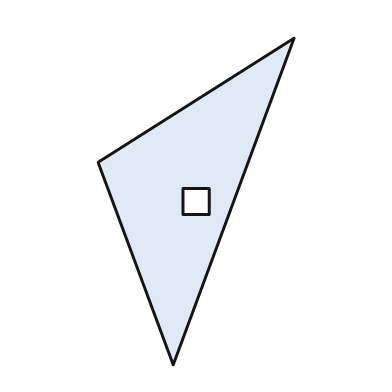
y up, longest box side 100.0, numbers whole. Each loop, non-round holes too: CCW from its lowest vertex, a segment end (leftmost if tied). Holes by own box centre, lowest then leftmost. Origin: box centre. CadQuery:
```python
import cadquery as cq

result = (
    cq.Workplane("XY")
    .moveTo(-7.0, -50.0)
    .lineTo(30.0, 50.0)
    .lineTo(-30.0, 12.0)
    .close()
    .moveTo(-4.0, -4.0)
    .lineTo(4.0, -4.0)
    .lineTo(4.0, 4.0)
    .lineTo(-4.0, 4.0)
    .close()
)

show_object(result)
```